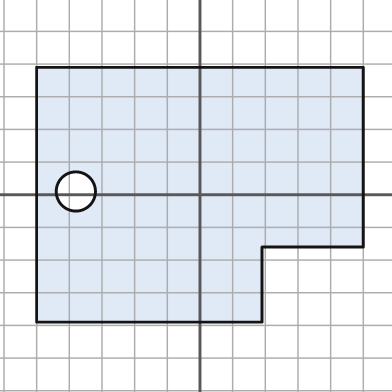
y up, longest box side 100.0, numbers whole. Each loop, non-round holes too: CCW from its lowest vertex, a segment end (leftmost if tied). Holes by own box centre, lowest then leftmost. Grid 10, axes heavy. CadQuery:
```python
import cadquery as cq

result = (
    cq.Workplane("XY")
    .moveTo(-50.0, -39.0)
    .lineTo(19.0, -39.0)
    .lineTo(19.0, -16.0)
    .lineTo(50.0, -16.0)
    .lineTo(50.0, 39.0)
    .lineTo(-50.0, 39.0)
    .close()
    .moveTo(-38.0, 1.0)
    .circle(6.0)
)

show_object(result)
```